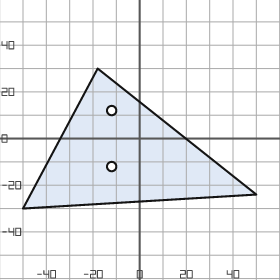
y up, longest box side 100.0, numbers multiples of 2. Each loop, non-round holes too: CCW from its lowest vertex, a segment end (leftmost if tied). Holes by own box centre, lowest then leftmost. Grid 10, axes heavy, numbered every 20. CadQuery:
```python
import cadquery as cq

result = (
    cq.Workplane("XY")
    .moveTo(-50.0, -30.0)
    .lineTo(50.0, -24.0)
    .lineTo(-18.0, 30.0)
    .close()
    .moveTo(-12.0, -12.0)
    .circle(2.0)
    .moveTo(-12.0, 12.0)
    .circle(2.0)
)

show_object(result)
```